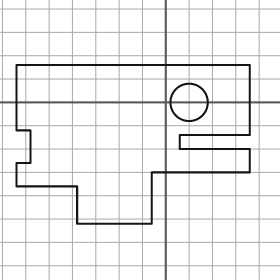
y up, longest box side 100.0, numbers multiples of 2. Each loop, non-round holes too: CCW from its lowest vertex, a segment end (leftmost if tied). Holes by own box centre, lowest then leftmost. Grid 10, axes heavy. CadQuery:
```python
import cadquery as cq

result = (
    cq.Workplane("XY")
    .moveTo(-38.0, -52.0)
    .lineTo(-6.0, -52.0)
    .lineTo(-6.0, -30.0)
    .lineTo(36.0, -30.0)
    .lineTo(36.0, -20.0)
    .lineTo(6.0, -20.0)
    .lineTo(6.0, -14.0)
    .lineTo(36.0, -14.0)
    .lineTo(36.0, 16.0)
    .lineTo(-64.0, 16.0)
    .lineTo(-64.0, -12.0)
    .lineTo(-58.0, -12.0)
    .lineTo(-58.0, -26.0)
    .lineTo(-64.0, -26.0)
    .lineTo(-64.0, -36.0)
    .lineTo(-38.0, -36.0)
    .close()
    .moveTo(10.0, 0.0)
    .circle(8.0)
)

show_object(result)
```